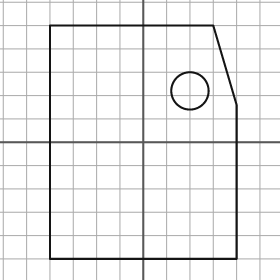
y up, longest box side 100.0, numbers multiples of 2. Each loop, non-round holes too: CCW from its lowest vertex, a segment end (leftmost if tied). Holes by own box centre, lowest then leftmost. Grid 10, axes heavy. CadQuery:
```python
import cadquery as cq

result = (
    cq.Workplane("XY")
    .moveTo(-40.0, -50.0)
    .lineTo(40.0, -50.0)
    .lineTo(40.0, 16.0)
    .lineTo(30.0, 50.0)
    .lineTo(-40.0, 50.0)
    .close()
    .moveTo(20.0, 22.0)
    .circle(8.0)
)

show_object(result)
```